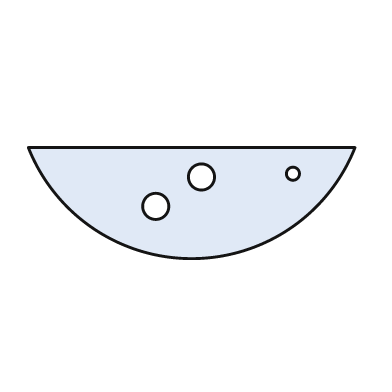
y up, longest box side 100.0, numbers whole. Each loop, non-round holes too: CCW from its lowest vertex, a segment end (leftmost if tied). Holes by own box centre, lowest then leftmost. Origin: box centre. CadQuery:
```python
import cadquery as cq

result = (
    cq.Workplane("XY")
    .moveTo(-50.0, 17.0)
    .threePointArc((0.0, -17.0), (50.0, 17.0))
    .close()
    .moveTo(-11.0, -1.0)
    .circle(4.0)
    .moveTo(3.0, 8.0)
    .circle(4.0)
    .moveTo(31.0, 9.0)
    .circle(2.0)
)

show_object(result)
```